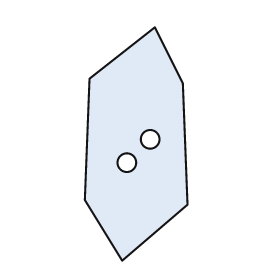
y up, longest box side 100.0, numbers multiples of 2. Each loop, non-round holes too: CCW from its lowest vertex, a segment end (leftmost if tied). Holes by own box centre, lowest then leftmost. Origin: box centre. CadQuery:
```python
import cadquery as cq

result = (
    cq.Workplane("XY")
    .moveTo(-6.0, -50.0)
    .lineTo(22.0, -26.0)
    .lineTo(20.0, 26.0)
    .lineTo(8.0, 50.0)
    .lineTo(-20.0, 28.0)
    .lineTo(-22.0, -24.0)
    .close()
    .moveTo(-4.0, -8.0)
    .circle(4.0)
    .moveTo(6.0, 2.0)
    .circle(4.0)
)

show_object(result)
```